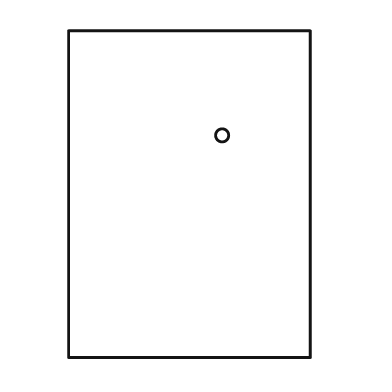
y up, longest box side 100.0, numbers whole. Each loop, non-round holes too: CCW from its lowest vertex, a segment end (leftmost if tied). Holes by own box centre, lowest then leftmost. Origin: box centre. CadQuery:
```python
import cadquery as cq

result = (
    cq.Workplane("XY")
    .moveTo(-37.0, -50.0)
    .lineTo(37.0, -50.0)
    .lineTo(37.0, 50.0)
    .lineTo(-37.0, 50.0)
    .close()
    .moveTo(10.0, 18.0)
    .circle(2.0)
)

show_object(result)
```